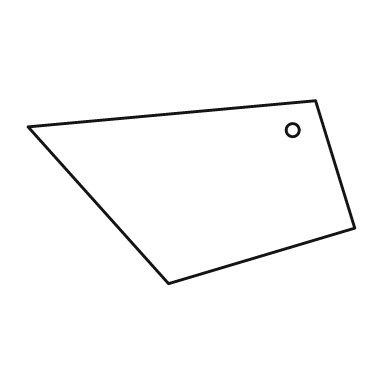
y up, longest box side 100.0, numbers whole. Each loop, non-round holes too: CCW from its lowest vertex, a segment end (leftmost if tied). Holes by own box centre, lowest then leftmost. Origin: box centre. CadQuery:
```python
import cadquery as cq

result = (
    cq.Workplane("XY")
    .moveTo(-7.0, -28.0)
    .lineTo(50.0, -11.0)
    .lineTo(38.0, 28.0)
    .lineTo(-50.0, 20.0)
    .close()
    .moveTo(31.0, 19.0)
    .circle(2.0)
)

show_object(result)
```